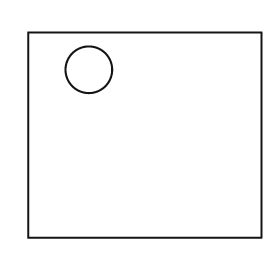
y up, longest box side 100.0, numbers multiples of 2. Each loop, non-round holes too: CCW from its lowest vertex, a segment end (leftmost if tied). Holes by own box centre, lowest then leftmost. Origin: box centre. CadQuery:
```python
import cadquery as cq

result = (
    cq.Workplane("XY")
    .moveTo(-50.0, -44.0)
    .lineTo(50.0, -44.0)
    .lineTo(50.0, 44.0)
    .lineTo(-50.0, 44.0)
    .close()
    .moveTo(-24.0, 28.0)
    .circle(10.0)
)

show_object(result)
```